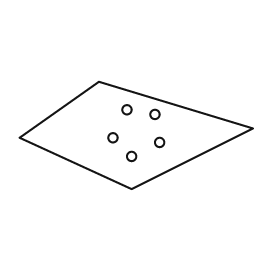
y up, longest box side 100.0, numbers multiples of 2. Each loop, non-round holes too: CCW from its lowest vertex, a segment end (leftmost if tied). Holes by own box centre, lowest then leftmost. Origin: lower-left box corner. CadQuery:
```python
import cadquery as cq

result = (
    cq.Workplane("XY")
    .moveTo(48.0, 0.0)
    .lineTo(100.0, 26.0)
    .lineTo(34.0, 46.0)
    .lineTo(0.0, 22.0)
    .close()
    .moveTo(48.0, 14.0)
    .circle(2.0)
    .moveTo(60.0, 20.0)
    .circle(2.0)
    .moveTo(40.0, 22.0)
    .circle(2.0)
    .moveTo(58.0, 32.0)
    .circle(2.0)
    .moveTo(46.0, 34.0)
    .circle(2.0)
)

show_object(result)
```